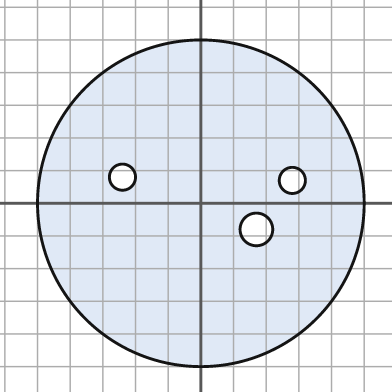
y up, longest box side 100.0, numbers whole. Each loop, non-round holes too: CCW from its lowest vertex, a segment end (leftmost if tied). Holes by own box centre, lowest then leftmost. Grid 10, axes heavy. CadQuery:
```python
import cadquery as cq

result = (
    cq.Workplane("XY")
    .moveTo(0.0, 0.0)
    .circle(50.0)
    .moveTo(17.0, -8.0)
    .circle(5.0)
    .moveTo(28.0, 7.0)
    .circle(4.0)
    .moveTo(-24.0, 8.0)
    .circle(4.0)
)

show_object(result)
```